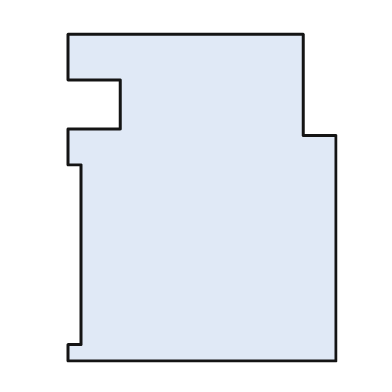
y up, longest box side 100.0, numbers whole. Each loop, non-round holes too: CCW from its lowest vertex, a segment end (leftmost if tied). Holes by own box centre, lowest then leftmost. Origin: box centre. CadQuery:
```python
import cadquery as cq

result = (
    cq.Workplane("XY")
    .moveTo(-41.0, -50.0)
    .lineTo(41.0, -50.0)
    .lineTo(41.0, 19.0)
    .lineTo(31.0, 19.0)
    .lineTo(31.0, 50.0)
    .lineTo(-41.0, 50.0)
    .lineTo(-41.0, 36.0)
    .lineTo(-25.0, 36.0)
    .lineTo(-25.0, 21.0)
    .lineTo(-41.0, 21.0)
    .lineTo(-41.0, 10.0)
    .lineTo(-37.0, 10.0)
    .lineTo(-37.0, -45.0)
    .lineTo(-41.0, -45.0)
    .close()
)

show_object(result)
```